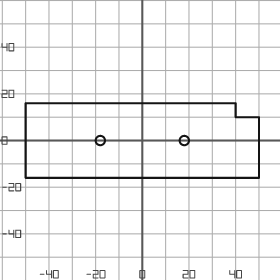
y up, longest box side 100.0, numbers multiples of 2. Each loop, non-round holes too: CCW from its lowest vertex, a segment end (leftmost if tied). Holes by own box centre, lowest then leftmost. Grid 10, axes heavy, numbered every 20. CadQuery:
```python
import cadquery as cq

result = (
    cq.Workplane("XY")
    .moveTo(-50.0, -16.0)
    .lineTo(50.0, -16.0)
    .lineTo(50.0, 10.0)
    .lineTo(40.0, 10.0)
    .lineTo(40.0, 16.0)
    .lineTo(-50.0, 16.0)
    .close()
    .moveTo(-18.0, 0.0)
    .circle(2.0)
    .moveTo(18.0, 0.0)
    .circle(2.0)
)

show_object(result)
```